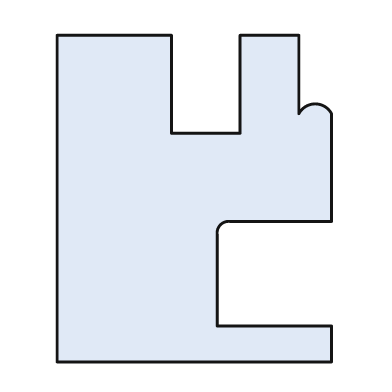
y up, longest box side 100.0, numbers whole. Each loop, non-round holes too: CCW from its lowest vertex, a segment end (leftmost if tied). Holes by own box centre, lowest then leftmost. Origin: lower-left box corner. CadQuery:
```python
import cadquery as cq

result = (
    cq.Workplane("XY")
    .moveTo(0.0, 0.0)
    .lineTo(84.0, 0.0)
    .lineTo(84.0, 11.0)
    .lineTo(49.0, 11.0)
    .lineTo(49.0, 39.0)
    .threePointArc((50.0, 42.0), (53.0, 43.0))
    .lineTo(84.0, 43.0)
    .lineTo(84.0, 76.0)
    .threePointArc((79.0, 79.0), (74.0, 76.0))
    .lineTo(74.0, 100.0)
    .lineTo(56.0, 100.0)
    .lineTo(56.0, 70.0)
    .lineTo(35.0, 70.0)
    .lineTo(35.0, 100.0)
    .lineTo(0.0, 100.0)
    .close()
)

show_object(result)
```